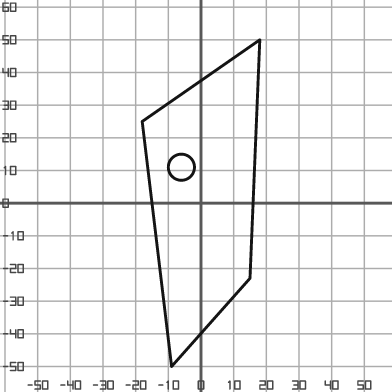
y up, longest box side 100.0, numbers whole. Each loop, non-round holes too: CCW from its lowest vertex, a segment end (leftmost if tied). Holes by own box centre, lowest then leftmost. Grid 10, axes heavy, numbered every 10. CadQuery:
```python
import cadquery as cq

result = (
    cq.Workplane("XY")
    .moveTo(-9.0, -50.0)
    .lineTo(15.0, -23.0)
    .lineTo(18.0, 50.0)
    .lineTo(-18.0, 25.0)
    .close()
    .moveTo(-6.0, 11.0)
    .circle(4.0)
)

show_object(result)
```